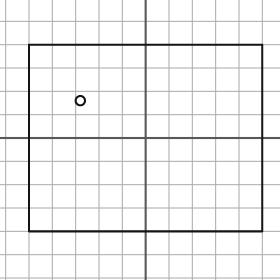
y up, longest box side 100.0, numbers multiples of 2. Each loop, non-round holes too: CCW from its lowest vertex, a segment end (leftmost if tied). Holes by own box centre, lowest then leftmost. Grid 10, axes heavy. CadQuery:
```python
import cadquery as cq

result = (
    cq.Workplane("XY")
    .moveTo(-50.0, -40.0)
    .lineTo(50.0, -40.0)
    .lineTo(50.0, 40.0)
    .lineTo(-50.0, 40.0)
    .close()
    .moveTo(-28.0, 16.0)
    .circle(2.0)
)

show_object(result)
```